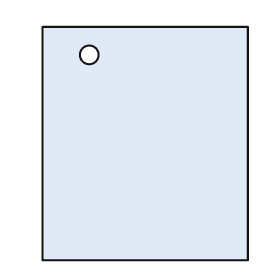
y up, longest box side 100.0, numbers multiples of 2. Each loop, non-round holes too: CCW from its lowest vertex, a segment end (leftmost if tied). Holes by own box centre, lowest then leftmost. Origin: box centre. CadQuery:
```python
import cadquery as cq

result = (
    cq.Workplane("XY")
    .moveTo(-44.0, -50.0)
    .lineTo(44.0, -50.0)
    .lineTo(44.0, 50.0)
    .lineTo(-44.0, 50.0)
    .close()
    .moveTo(-24.0, 38.0)
    .circle(4.0)
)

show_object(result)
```